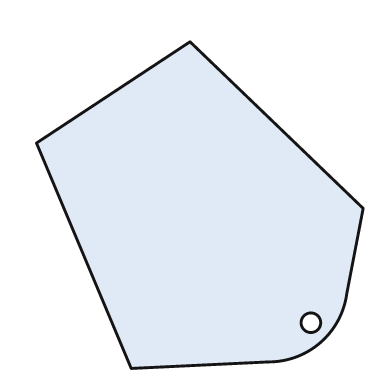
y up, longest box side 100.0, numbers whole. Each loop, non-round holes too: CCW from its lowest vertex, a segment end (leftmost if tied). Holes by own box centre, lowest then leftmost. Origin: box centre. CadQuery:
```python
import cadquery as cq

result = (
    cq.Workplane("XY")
    .moveTo(-21.0, -50.0)
    .lineTo(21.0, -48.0)
    .threePointArc((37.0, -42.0), (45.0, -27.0))
    .lineTo(50.0, -1.0)
    .lineTo(-3.0, 50.0)
    .lineTo(-50.0, 19.0)
    .close()
    .moveTo(34.0, -36.0)
    .circle(3.0)
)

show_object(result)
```